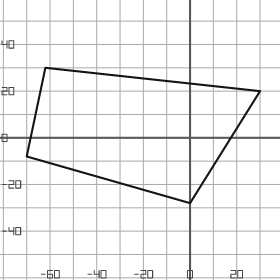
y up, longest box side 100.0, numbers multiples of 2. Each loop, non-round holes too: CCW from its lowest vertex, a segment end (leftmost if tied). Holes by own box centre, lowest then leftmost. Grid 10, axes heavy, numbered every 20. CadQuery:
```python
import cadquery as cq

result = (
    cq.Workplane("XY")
    .moveTo(0.0, -28.0)
    .lineTo(30.0, 20.0)
    .lineTo(-62.0, 30.0)
    .lineTo(-70.0, -8.0)
    .close()
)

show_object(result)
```